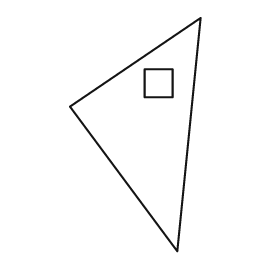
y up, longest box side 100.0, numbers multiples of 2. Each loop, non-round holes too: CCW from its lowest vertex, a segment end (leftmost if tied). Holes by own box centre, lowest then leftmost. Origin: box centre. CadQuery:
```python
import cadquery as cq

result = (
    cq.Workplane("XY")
    .moveTo(18.0, -50.0)
    .lineTo(28.0, 50.0)
    .lineTo(-28.0, 12.0)
    .close()
    .moveTo(4.0, 16.0)
    .lineTo(16.0, 16.0)
    .lineTo(16.0, 28.0)
    .lineTo(4.0, 28.0)
    .close()
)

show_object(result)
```